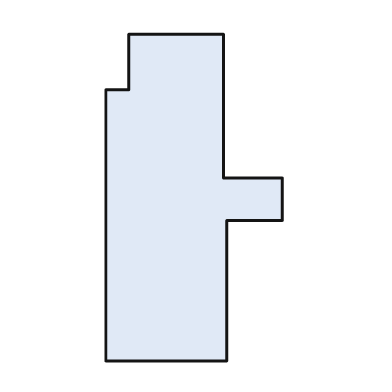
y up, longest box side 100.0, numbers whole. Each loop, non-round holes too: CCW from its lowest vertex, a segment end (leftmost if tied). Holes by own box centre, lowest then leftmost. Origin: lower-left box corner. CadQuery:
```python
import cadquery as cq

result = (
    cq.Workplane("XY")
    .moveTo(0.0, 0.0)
    .lineTo(37.0, 0.0)
    .lineTo(37.0, 43.0)
    .lineTo(54.0, 43.0)
    .lineTo(54.0, 56.0)
    .lineTo(36.0, 56.0)
    .lineTo(36.0, 100.0)
    .lineTo(7.0, 100.0)
    .lineTo(7.0, 83.0)
    .lineTo(0.0, 83.0)
    .close()
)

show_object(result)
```